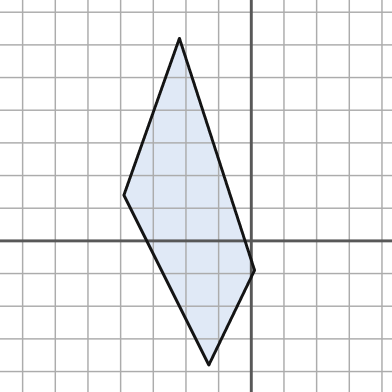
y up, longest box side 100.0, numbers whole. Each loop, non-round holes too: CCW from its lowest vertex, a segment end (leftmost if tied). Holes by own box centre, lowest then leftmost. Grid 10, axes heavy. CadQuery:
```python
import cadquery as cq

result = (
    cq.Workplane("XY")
    .moveTo(-13.0, -38.0)
    .lineTo(1.0, -9.0)
    .lineTo(-22.0, 62.0)
    .lineTo(-39.0, 14.0)
    .close()
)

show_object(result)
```